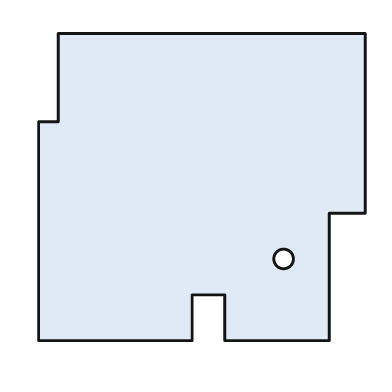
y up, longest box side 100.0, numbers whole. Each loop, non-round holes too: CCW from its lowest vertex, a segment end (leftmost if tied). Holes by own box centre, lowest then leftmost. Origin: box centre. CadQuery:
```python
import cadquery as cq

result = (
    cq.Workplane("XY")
    .moveTo(-50.0, -47.0)
    .lineTo(-3.0, -47.0)
    .lineTo(-3.0, -33.0)
    .lineTo(7.0, -33.0)
    .lineTo(7.0, -47.0)
    .lineTo(39.0, -47.0)
    .lineTo(39.0, -8.0)
    .lineTo(50.0, -8.0)
    .lineTo(50.0, 47.0)
    .lineTo(-44.0, 47.0)
    .lineTo(-44.0, 20.0)
    .lineTo(-50.0, 20.0)
    .close()
    .moveTo(25.0, -22.0)
    .circle(3.0)
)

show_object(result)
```